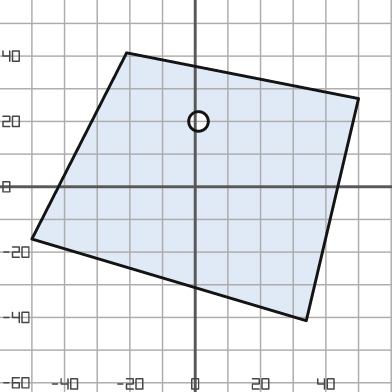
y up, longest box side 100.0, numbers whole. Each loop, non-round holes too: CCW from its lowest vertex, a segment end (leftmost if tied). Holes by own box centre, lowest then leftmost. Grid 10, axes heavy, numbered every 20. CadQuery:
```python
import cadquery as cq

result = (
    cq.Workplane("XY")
    .moveTo(34.0, -41.0)
    .lineTo(50.0, 27.0)
    .lineTo(-21.0, 41.0)
    .lineTo(-50.0, -16.0)
    .close()
    .moveTo(1.0, 20.0)
    .circle(3.0)
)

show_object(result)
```